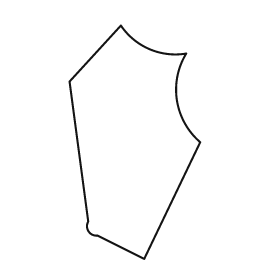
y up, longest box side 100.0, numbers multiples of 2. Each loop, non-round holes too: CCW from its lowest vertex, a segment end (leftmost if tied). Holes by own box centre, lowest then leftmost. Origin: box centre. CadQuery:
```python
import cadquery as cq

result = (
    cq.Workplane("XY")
    .moveTo(4.0, -50.0)
    .lineTo(28.0, 0.0)
    .threePointArc((18.0, 18.0), (22.0, 38.0))
    .threePointArc((6.0, 40.0), (-6.0, 50.0))
    .lineTo(-28.0, 26.0)
    .lineTo(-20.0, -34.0)
    .threePointArc((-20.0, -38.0), (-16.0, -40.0))
    .close()
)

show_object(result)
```